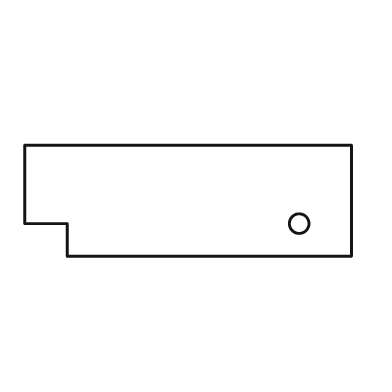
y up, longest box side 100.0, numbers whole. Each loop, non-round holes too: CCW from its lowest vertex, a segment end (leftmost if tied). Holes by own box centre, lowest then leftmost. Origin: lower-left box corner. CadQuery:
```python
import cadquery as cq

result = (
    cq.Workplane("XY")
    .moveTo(13.0, 0.0)
    .lineTo(100.0, 0.0)
    .lineTo(100.0, 34.0)
    .lineTo(0.0, 34.0)
    .lineTo(0.0, 10.0)
    .lineTo(13.0, 10.0)
    .close()
    .moveTo(84.0, 10.0)
    .circle(3.0)
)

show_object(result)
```